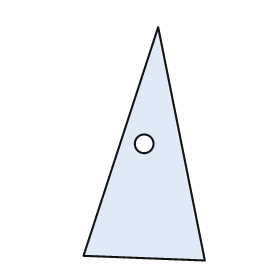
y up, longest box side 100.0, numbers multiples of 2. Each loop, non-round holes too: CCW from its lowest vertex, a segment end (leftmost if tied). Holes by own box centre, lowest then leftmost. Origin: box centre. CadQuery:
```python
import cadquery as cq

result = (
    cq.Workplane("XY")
    .moveTo(26.0, -50.0)
    .lineTo(6.0, 50.0)
    .lineTo(-26.0, -48.0)
    .close()
    .moveTo(0.0, 0.0)
    .circle(4.0)
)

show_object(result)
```